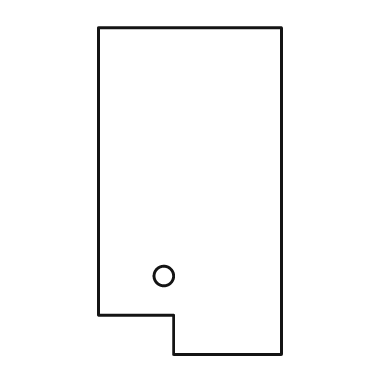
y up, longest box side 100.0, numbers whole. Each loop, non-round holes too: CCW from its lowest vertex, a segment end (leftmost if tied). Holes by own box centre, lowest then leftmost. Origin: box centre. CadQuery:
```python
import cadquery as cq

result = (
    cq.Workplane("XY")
    .moveTo(-5.0, -50.0)
    .lineTo(28.0, -50.0)
    .lineTo(28.0, 50.0)
    .lineTo(-28.0, 50.0)
    .lineTo(-28.0, -38.0)
    .lineTo(-5.0, -38.0)
    .close()
    .moveTo(-8.0, -26.0)
    .circle(3.0)
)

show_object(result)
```